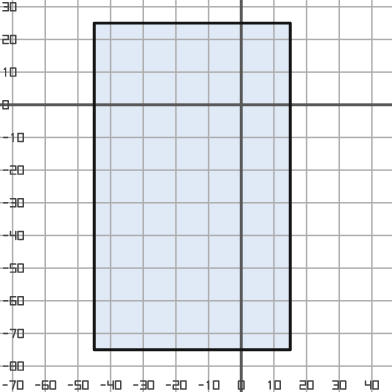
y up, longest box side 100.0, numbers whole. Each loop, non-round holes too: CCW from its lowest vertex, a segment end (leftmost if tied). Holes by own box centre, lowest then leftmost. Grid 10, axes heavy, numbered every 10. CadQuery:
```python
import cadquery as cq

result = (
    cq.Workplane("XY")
    .moveTo(-45.0, -75.0)
    .lineTo(15.0, -75.0)
    .lineTo(15.0, 25.0)
    .lineTo(-45.0, 25.0)
    .close()
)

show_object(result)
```